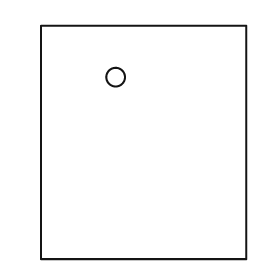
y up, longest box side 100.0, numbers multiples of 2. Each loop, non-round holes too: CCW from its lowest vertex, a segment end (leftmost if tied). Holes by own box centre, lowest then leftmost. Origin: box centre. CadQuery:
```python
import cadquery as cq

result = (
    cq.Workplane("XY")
    .moveTo(-44.0, -50.0)
    .lineTo(44.0, -50.0)
    .lineTo(44.0, 50.0)
    .lineTo(-44.0, 50.0)
    .close()
    .moveTo(-12.0, 28.0)
    .circle(4.0)
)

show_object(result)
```